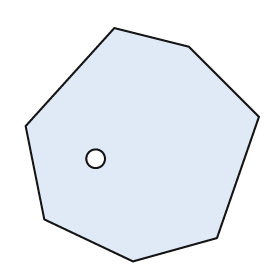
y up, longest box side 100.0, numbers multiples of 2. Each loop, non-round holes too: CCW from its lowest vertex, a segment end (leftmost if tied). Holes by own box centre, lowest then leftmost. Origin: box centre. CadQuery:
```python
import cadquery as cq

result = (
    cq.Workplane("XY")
    .moveTo(-4.0, -50.0)
    .lineTo(32.0, -40.0)
    .lineTo(50.0, 12.0)
    .lineTo(20.0, 42.0)
    .lineTo(-12.0, 50.0)
    .lineTo(-50.0, 8.0)
    .lineTo(-42.0, -32.0)
    .close()
    .moveTo(-20.0, -6.0)
    .circle(4.0)
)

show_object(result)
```